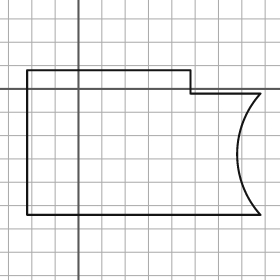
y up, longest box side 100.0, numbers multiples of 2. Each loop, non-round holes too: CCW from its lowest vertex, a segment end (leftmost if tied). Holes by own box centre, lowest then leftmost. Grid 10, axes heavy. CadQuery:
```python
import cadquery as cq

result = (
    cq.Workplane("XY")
    .moveTo(-22.0, -54.0)
    .lineTo(78.0, -54.0)
    .threePointArc((68.0, -28.0), (78.0, -2.0))
    .lineTo(48.0, -2.0)
    .lineTo(48.0, 8.0)
    .lineTo(-22.0, 8.0)
    .close()
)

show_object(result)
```